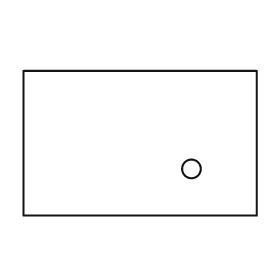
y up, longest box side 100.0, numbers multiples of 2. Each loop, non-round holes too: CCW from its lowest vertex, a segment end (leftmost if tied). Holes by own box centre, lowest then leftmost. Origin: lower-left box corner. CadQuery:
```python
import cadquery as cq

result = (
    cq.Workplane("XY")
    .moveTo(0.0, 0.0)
    .lineTo(100.0, 0.0)
    .lineTo(100.0, 62.0)
    .lineTo(0.0, 62.0)
    .close()
    .moveTo(72.0, 20.0)
    .circle(4.0)
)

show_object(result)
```